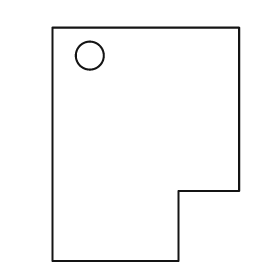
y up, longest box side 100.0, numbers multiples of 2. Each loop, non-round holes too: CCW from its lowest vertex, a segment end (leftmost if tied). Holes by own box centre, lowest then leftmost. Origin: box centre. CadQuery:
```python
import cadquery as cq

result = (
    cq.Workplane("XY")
    .moveTo(-40.0, -50.0)
    .lineTo(14.0, -50.0)
    .lineTo(14.0, -20.0)
    .lineTo(40.0, -20.0)
    .lineTo(40.0, 50.0)
    .lineTo(-40.0, 50.0)
    .close()
    .moveTo(-24.0, 38.0)
    .circle(6.0)
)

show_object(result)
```